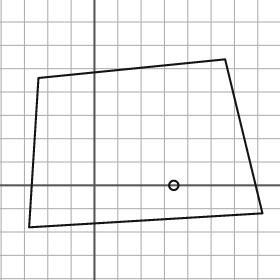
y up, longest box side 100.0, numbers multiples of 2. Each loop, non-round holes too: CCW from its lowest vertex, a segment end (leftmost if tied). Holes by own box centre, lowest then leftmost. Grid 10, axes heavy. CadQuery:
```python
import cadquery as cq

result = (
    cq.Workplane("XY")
    .moveTo(-28.0, -18.0)
    .lineTo(72.0, -12.0)
    .lineTo(56.0, 54.0)
    .lineTo(-24.0, 46.0)
    .close()
    .moveTo(34.0, 0.0)
    .circle(2.0)
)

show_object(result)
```